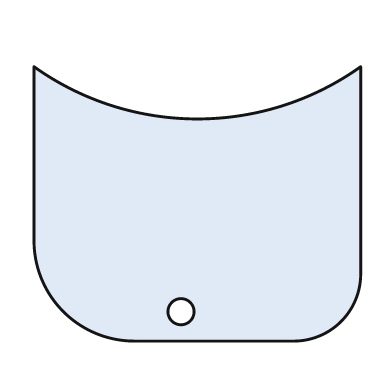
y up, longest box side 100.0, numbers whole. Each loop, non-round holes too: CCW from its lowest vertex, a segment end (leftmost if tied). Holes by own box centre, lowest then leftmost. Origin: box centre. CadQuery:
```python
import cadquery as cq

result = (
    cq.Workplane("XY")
    .moveTo(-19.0, -42.0)
    .lineTo(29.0, -42.0)
    .threePointArc((44.0, -36.0), (50.0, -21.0))
    .lineTo(50.0, 42.0)
    .threePointArc((0.0, 26.0), (-50.0, 42.0))
    .lineTo(-50.0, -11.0)
    .threePointArc((-41.0, -33.0), (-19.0, -42.0))
    .close()
    .moveTo(-5.0, -33.0)
    .circle(4.0)
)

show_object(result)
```